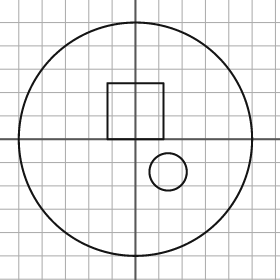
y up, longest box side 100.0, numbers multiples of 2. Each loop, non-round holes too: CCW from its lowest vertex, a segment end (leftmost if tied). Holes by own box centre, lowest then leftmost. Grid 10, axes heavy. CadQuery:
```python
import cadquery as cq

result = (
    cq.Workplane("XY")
    .moveTo(0.0, 0.0)
    .circle(50.0)
    .moveTo(14.0, -14.0)
    .circle(8.0)
    .moveTo(-12.0, 0.0)
    .lineTo(12.0, 0.0)
    .lineTo(12.0, 24.0)
    .lineTo(-12.0, 24.0)
    .close()
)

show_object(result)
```